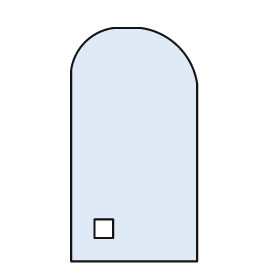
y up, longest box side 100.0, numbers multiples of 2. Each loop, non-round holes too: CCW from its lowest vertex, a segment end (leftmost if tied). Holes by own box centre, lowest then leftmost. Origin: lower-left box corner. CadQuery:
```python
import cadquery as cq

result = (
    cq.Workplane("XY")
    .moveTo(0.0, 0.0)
    .lineTo(54.0, 0.0)
    .lineTo(54.0, 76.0)
    .threePointArc((46.0, 92.0), (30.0, 100.0))
    .lineTo(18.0, 100.0)
    .threePointArc((6.0, 94.0), (0.0, 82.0))
    .close()
    .moveTo(10.0, 10.0)
    .lineTo(18.0, 10.0)
    .lineTo(18.0, 18.0)
    .lineTo(10.0, 18.0)
    .close()
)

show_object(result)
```